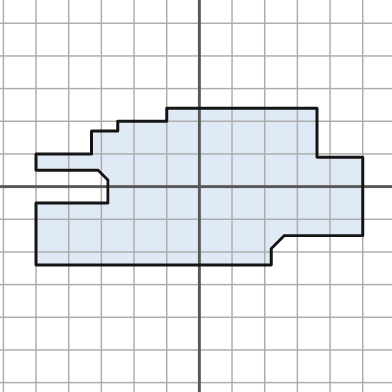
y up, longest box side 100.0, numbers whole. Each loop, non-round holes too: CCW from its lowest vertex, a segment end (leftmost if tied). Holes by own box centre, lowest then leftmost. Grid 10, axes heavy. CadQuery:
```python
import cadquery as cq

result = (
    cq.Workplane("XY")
    .moveTo(-50.0, -24.0)
    .lineTo(22.0, -24.0)
    .lineTo(22.0, -19.0)
    .lineTo(26.0, -15.0)
    .lineTo(50.0, -15.0)
    .lineTo(50.0, 9.0)
    .lineTo(36.0, 9.0)
    .lineTo(36.0, 24.0)
    .lineTo(-10.0, 24.0)
    .lineTo(-10.0, 20.0)
    .lineTo(-25.0, 20.0)
    .lineTo(-25.0, 17.0)
    .lineTo(-33.0, 17.0)
    .lineTo(-33.0, 10.0)
    .lineTo(-50.0, 10.0)
    .lineTo(-50.0, 5.0)
    .lineTo(-31.0, 5.0)
    .lineTo(-28.0, 2.0)
    .lineTo(-28.0, -5.0)
    .lineTo(-50.0, -5.0)
    .close()
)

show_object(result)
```